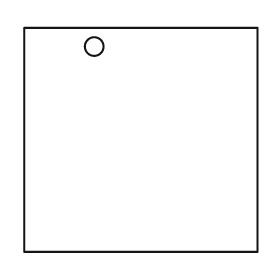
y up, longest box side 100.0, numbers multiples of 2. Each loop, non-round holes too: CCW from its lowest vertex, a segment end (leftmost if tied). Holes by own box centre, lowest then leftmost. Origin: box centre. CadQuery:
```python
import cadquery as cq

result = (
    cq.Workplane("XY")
    .moveTo(-50.0, -48.0)
    .lineTo(50.0, -48.0)
    .lineTo(50.0, 48.0)
    .lineTo(-50.0, 48.0)
    .close()
    .moveTo(-20.0, 40.0)
    .circle(4.0)
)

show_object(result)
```